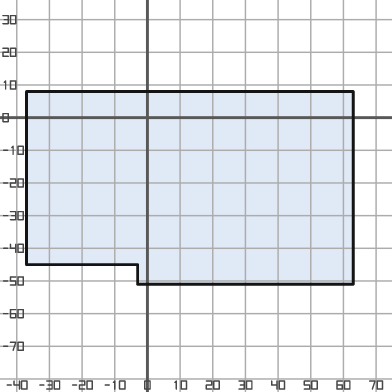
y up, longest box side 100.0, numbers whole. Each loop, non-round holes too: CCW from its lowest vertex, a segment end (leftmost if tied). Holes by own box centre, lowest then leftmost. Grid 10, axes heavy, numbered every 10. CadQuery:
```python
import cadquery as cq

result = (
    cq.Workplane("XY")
    .moveTo(-3.0, -51.0)
    .lineTo(63.0, -51.0)
    .lineTo(63.0, 8.0)
    .lineTo(-37.0, 8.0)
    .lineTo(-37.0, -45.0)
    .lineTo(-3.0, -45.0)
    .close()
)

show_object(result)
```